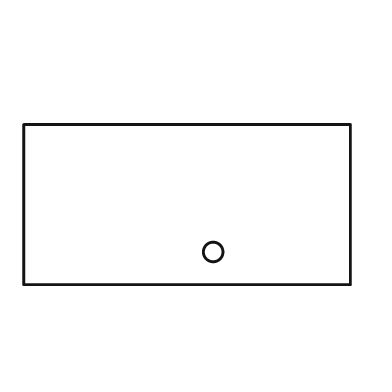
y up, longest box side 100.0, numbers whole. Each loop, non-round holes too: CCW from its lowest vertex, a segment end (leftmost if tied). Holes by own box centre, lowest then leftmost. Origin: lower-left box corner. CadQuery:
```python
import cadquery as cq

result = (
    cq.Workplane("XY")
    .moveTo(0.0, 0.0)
    .lineTo(100.0, 0.0)
    .lineTo(100.0, 49.0)
    .lineTo(0.0, 49.0)
    .close()
    .moveTo(58.0, 10.0)
    .circle(3.0)
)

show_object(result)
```